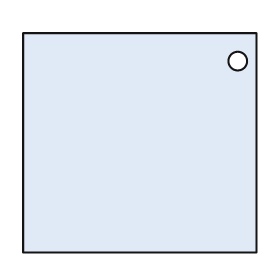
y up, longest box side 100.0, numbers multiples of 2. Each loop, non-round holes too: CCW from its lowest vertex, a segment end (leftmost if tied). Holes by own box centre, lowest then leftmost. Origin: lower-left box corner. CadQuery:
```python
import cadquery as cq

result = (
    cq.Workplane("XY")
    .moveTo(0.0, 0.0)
    .lineTo(100.0, 0.0)
    .lineTo(100.0, 94.0)
    .lineTo(0.0, 94.0)
    .close()
    .moveTo(92.0, 82.0)
    .circle(4.0)
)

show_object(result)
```